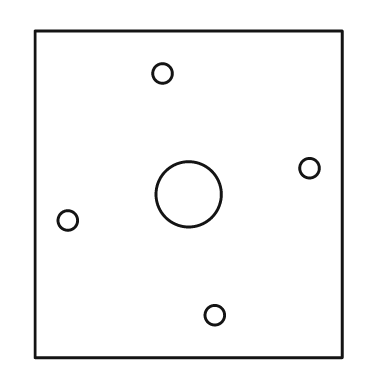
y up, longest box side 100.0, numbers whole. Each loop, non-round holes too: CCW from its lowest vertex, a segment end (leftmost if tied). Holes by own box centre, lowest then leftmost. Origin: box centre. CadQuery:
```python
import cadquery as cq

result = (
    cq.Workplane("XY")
    .moveTo(-47.0, -50.0)
    .lineTo(47.0, -50.0)
    .lineTo(47.0, 50.0)
    .lineTo(-47.0, 50.0)
    .close()
    .moveTo(8.0, -37.0)
    .circle(3.0)
    .moveTo(-37.0, -8.0)
    .circle(3.0)
    .moveTo(0.0, 0.0)
    .circle(10.0)
    .moveTo(37.0, 8.0)
    .circle(3.0)
    .moveTo(-8.0, 37.0)
    .circle(3.0)
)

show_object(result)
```